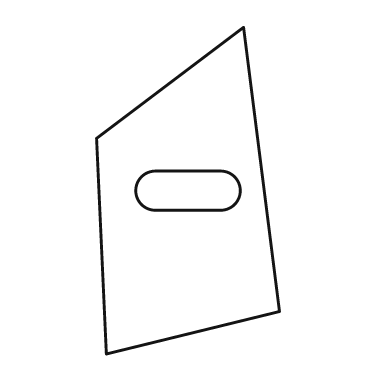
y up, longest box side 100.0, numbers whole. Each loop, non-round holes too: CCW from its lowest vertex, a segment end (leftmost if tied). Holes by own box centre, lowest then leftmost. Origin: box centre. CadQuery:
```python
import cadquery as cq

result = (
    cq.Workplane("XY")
    .moveTo(-25.0, -50.0)
    .lineTo(28.0, -37.0)
    .lineTo(17.0, 50.0)
    .lineTo(-28.0, 16.0)
    .close()
    .moveTo(-10.0, -6.0)
    .lineTo(10.0, -6.0)
    .threePointArc((16.0, 0.0), (10.0, 6.0))
    .lineTo(-10.0, 6.0)
    .threePointArc((-16.0, 0.0), (-10.0, -6.0))
    .close()
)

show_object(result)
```